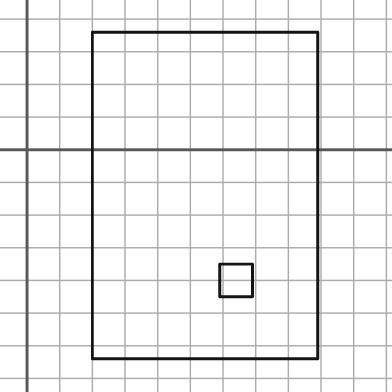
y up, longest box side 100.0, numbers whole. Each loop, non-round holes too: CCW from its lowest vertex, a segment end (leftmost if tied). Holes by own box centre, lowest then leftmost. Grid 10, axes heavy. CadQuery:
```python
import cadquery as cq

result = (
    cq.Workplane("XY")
    .moveTo(20.0, -64.0)
    .lineTo(89.0, -64.0)
    .lineTo(89.0, 36.0)
    .lineTo(20.0, 36.0)
    .close()
    .moveTo(59.0, -45.0)
    .lineTo(69.0, -45.0)
    .lineTo(69.0, -35.0)
    .lineTo(59.0, -35.0)
    .close()
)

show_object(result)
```